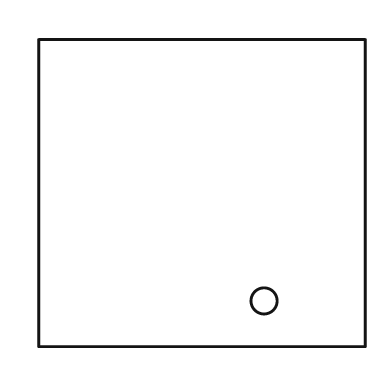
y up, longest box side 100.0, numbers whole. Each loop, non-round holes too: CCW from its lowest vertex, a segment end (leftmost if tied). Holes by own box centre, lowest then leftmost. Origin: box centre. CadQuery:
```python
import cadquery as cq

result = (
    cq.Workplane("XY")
    .moveTo(-50.0, -47.0)
    .lineTo(50.0, -47.0)
    .lineTo(50.0, 47.0)
    .lineTo(-50.0, 47.0)
    .close()
    .moveTo(19.0, -33.0)
    .circle(4.0)
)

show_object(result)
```